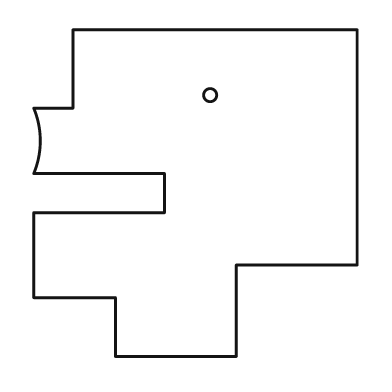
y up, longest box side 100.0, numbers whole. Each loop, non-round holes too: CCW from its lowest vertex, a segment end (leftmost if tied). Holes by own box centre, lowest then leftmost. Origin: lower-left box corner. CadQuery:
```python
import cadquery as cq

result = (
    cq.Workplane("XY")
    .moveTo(25.0, 0.0)
    .lineTo(62.0, 0.0)
    .lineTo(62.0, 28.0)
    .lineTo(99.0, 28.0)
    .lineTo(99.0, 100.0)
    .lineTo(12.0, 100.0)
    .lineTo(12.0, 76.0)
    .lineTo(0.0, 76.0)
    .threePointArc((2.0, 66.0), (0.0, 56.0))
    .lineTo(40.0, 56.0)
    .lineTo(40.0, 44.0)
    .lineTo(0.0, 44.0)
    .lineTo(0.0, 18.0)
    .lineTo(25.0, 18.0)
    .close()
    .moveTo(54.0, 80.0)
    .circle(2.0)
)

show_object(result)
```